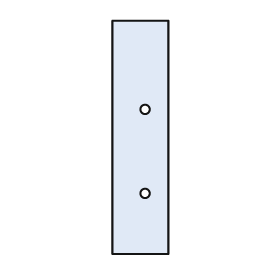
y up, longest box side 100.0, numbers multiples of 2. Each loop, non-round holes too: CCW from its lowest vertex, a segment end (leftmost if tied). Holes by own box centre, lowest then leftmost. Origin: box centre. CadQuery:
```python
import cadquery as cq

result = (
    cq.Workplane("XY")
    .moveTo(-12.0, -50.0)
    .lineTo(12.0, -50.0)
    .lineTo(12.0, 50.0)
    .lineTo(-12.0, 50.0)
    .close()
    .moveTo(2.0, -24.0)
    .circle(2.0)
    .moveTo(2.0, 12.0)
    .circle(2.0)
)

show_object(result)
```